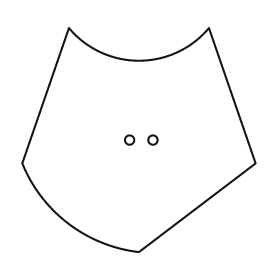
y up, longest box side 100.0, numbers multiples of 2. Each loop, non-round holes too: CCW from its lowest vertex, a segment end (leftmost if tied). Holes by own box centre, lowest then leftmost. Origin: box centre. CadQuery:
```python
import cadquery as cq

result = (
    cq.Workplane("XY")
    .moveTo(0.0, -48.0)
    .lineTo(50.0, -10.0)
    .lineTo(30.0, 48.0)
    .threePointArc((0.0, 34.0), (-30.0, 48.0))
    .lineTo(-50.0, -10.0)
    .threePointArc((-30.0, -36.0), (0.0, -48.0))
    .close()
    .moveTo(-4.0, 0.0)
    .circle(2.0)
    .moveTo(6.0, 0.0)
    .circle(2.0)
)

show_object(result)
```